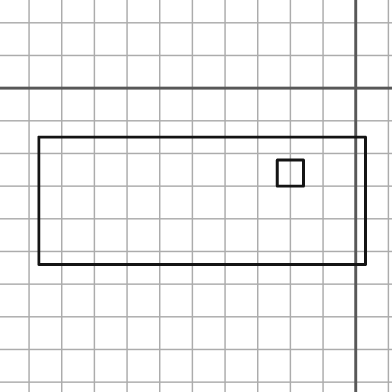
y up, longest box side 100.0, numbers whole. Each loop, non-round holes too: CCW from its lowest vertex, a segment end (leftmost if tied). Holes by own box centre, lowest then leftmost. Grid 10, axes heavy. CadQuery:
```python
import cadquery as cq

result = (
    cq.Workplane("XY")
    .moveTo(-97.0, -54.0)
    .lineTo(3.0, -54.0)
    .lineTo(3.0, -15.0)
    .lineTo(-97.0, -15.0)
    .close()
    .moveTo(-24.0, -30.0)
    .lineTo(-16.0, -30.0)
    .lineTo(-16.0, -22.0)
    .lineTo(-24.0, -22.0)
    .close()
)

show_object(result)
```